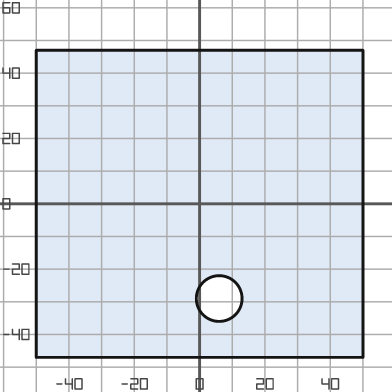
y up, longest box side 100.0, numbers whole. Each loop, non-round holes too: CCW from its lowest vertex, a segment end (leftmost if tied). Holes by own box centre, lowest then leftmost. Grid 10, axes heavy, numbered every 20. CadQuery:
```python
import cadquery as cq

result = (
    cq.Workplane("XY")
    .moveTo(-50.0, -47.0)
    .lineTo(50.0, -47.0)
    .lineTo(50.0, 47.0)
    .lineTo(-50.0, 47.0)
    .close()
    .moveTo(6.0, -29.0)
    .circle(7.0)
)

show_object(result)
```